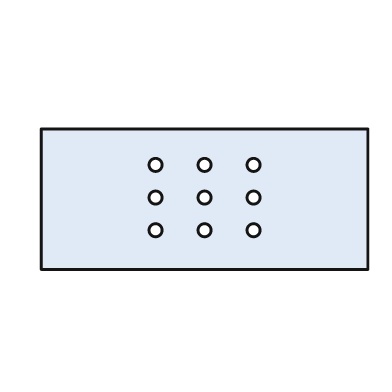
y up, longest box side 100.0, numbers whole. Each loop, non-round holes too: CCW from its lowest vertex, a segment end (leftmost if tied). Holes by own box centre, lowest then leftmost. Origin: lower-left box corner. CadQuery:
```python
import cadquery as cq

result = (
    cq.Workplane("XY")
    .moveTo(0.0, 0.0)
    .lineTo(100.0, 0.0)
    .lineTo(100.0, 43.0)
    .lineTo(0.0, 43.0)
    .close()
    .moveTo(35.0, 12.0)
    .circle(2.0)
    .moveTo(50.0, 12.0)
    .circle(2.0)
    .moveTo(65.0, 12.0)
    .circle(2.0)
    .moveTo(35.0, 22.0)
    .circle(2.0)
    .moveTo(50.0, 22.0)
    .circle(2.0)
    .moveTo(65.0, 22.0)
    .circle(2.0)
    .moveTo(35.0, 32.0)
    .circle(2.0)
    .moveTo(50.0, 32.0)
    .circle(2.0)
    .moveTo(65.0, 32.0)
    .circle(2.0)
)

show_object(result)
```